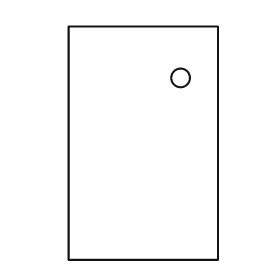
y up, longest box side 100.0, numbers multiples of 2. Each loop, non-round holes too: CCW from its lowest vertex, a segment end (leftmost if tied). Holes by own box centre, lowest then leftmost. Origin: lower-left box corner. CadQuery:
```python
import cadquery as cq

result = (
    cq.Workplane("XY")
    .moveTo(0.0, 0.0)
    .lineTo(64.0, 0.0)
    .lineTo(64.0, 100.0)
    .lineTo(0.0, 100.0)
    .close()
    .moveTo(48.0, 78.0)
    .circle(4.0)
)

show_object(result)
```